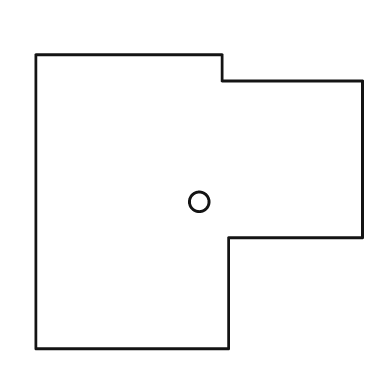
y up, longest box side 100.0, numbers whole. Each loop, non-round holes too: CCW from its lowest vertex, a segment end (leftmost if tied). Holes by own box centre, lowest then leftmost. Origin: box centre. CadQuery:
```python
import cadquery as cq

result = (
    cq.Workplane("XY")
    .moveTo(-50.0, -45.0)
    .lineTo(9.0, -45.0)
    .lineTo(9.0, -11.0)
    .lineTo(50.0, -11.0)
    .lineTo(50.0, 37.0)
    .lineTo(7.0, 37.0)
    .lineTo(7.0, 45.0)
    .lineTo(-50.0, 45.0)
    .close()
    .moveTo(0.0, 0.0)
    .circle(3.0)
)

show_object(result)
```